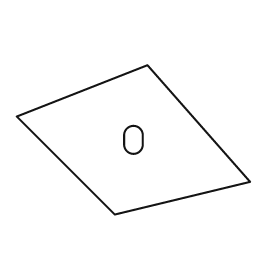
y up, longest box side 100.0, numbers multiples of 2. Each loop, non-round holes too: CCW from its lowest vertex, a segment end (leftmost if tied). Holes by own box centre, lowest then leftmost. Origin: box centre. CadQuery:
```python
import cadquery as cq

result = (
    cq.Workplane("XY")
    .moveTo(-8.0, -32.0)
    .lineTo(50.0, -18.0)
    .lineTo(6.0, 32.0)
    .lineTo(-50.0, 10.0)
    .close()
    .moveTo(-4.0, -2.0)
    .threePointArc((0.0, -6.0), (4.0, -2.0))
    .lineTo(4.0, 2.0)
    .threePointArc((0.0, 6.0), (-4.0, 2.0))
    .close()
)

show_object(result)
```